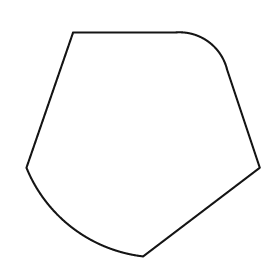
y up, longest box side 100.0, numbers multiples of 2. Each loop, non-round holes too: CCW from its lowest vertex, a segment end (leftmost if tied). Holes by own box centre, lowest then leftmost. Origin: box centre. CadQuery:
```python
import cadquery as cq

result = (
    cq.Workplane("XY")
    .moveTo(0.0, -48.0)
    .lineTo(50.0, -10.0)
    .lineTo(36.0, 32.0)
    .threePointArc((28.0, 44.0), (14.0, 48.0))
    .lineTo(-30.0, 48.0)
    .lineTo(-50.0, -10.0)
    .threePointArc((-30.0, -36.0), (0.0, -48.0))
    .close()
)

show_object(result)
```